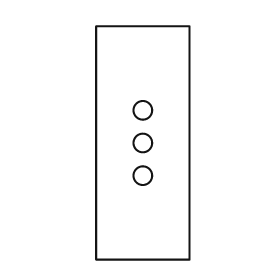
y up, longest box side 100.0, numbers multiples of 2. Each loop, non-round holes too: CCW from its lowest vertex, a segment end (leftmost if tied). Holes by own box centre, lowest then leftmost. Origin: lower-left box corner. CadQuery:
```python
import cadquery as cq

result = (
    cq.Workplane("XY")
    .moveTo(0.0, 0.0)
    .lineTo(40.0, 0.0)
    .lineTo(40.0, 100.0)
    .lineTo(0.0, 100.0)
    .close()
    .moveTo(20.0, 36.0)
    .circle(4.0)
    .moveTo(20.0, 50.0)
    .circle(4.0)
    .moveTo(20.0, 64.0)
    .circle(4.0)
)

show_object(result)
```